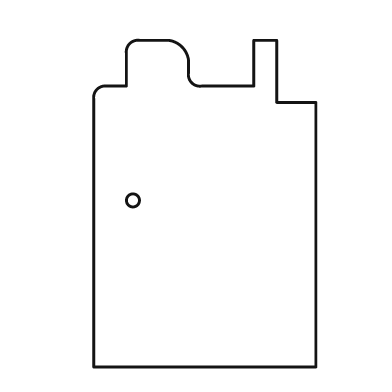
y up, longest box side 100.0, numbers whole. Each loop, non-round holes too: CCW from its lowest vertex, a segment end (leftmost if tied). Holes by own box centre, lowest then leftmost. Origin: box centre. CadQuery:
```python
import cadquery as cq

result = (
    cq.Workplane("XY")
    .moveTo(-34.0, -50.0)
    .lineTo(34.0, -50.0)
    .lineTo(34.0, 31.0)
    .lineTo(22.0, 31.0)
    .lineTo(22.0, 50.0)
    .lineTo(15.0, 50.0)
    .lineTo(15.0, 36.0)
    .lineTo(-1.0, 36.0)
    .threePointArc((-4.0, 37.0), (-5.0, 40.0))
    .lineTo(-5.0, 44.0)
    .threePointArc((-7.0, 48.0), (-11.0, 50.0))
    .lineTo(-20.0, 50.0)
    .threePointArc((-23.0, 49.0), (-24.0, 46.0))
    .lineTo(-24.0, 36.0)
    .lineTo(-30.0, 36.0)
    .threePointArc((-33.0, 35.0), (-34.0, 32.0))
    .close()
    .moveTo(-22.0, 1.0)
    .circle(2.0)
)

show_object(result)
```